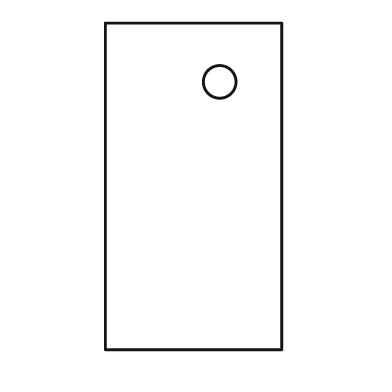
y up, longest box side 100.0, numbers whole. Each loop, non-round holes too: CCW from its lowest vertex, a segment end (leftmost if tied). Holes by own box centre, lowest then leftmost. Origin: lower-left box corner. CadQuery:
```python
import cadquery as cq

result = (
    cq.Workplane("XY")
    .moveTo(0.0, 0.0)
    .lineTo(54.0, 0.0)
    .lineTo(54.0, 100.0)
    .lineTo(0.0, 100.0)
    .close()
    .moveTo(35.0, 82.0)
    .circle(5.0)
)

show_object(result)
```